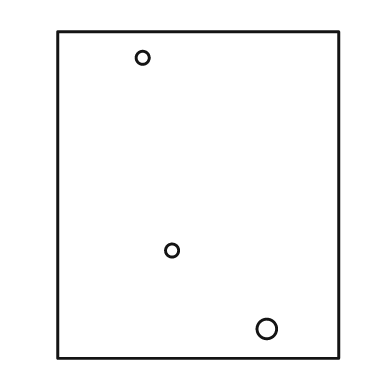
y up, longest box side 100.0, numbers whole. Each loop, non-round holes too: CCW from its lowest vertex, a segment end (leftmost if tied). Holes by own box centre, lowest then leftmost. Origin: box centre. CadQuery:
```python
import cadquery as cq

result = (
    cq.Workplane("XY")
    .moveTo(-43.0, -50.0)
    .lineTo(43.0, -50.0)
    .lineTo(43.0, 50.0)
    .lineTo(-43.0, 50.0)
    .close()
    .moveTo(21.0, -41.0)
    .circle(3.0)
    .moveTo(-8.0, -17.0)
    .circle(2.0)
    .moveTo(-17.0, 42.0)
    .circle(2.0)
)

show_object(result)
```